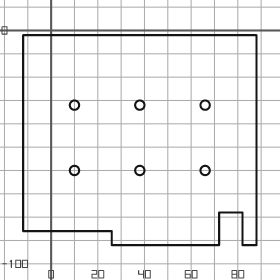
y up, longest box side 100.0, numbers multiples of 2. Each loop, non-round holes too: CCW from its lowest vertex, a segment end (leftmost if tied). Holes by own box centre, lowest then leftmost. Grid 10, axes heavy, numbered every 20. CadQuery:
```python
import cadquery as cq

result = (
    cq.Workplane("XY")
    .moveTo(26.0, -92.0)
    .lineTo(72.0, -92.0)
    .lineTo(72.0, -78.0)
    .lineTo(82.0, -78.0)
    .lineTo(82.0, -92.0)
    .lineTo(88.0, -92.0)
    .lineTo(88.0, -2.0)
    .lineTo(-12.0, -2.0)
    .lineTo(-12.0, -86.0)
    .lineTo(26.0, -86.0)
    .close()
    .moveTo(10.0, -60.0)
    .circle(2.0)
    .moveTo(38.0, -60.0)
    .circle(2.0)
    .moveTo(66.0, -60.0)
    .circle(2.0)
    .moveTo(10.0, -32.0)
    .circle(2.0)
    .moveTo(38.0, -32.0)
    .circle(2.0)
    .moveTo(66.0, -32.0)
    .circle(2.0)
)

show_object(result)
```